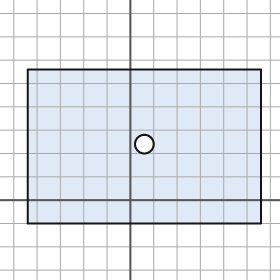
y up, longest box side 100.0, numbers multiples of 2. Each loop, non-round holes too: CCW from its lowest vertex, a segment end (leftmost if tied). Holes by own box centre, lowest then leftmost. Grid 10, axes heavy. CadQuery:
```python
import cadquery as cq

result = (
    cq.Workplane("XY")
    .moveTo(-44.0, -10.0)
    .lineTo(56.0, -10.0)
    .lineTo(56.0, 56.0)
    .lineTo(-44.0, 56.0)
    .close()
    .moveTo(6.0, 24.0)
    .circle(4.0)
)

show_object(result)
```